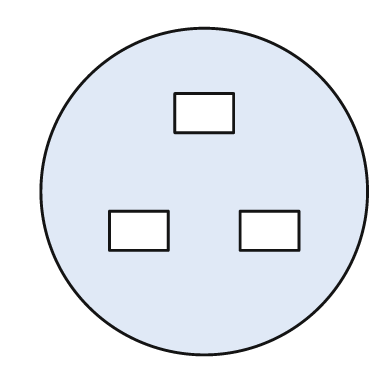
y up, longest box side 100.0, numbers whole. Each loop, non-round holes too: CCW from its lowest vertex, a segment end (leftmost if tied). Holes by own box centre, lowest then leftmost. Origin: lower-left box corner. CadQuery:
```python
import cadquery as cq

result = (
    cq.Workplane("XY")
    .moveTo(50.0, 50.0)
    .circle(50.0)
    .moveTo(21.0, 32.0)
    .lineTo(39.0, 32.0)
    .lineTo(39.0, 44.0)
    .lineTo(21.0, 44.0)
    .close()
    .moveTo(61.0, 32.0)
    .lineTo(79.0, 32.0)
    .lineTo(79.0, 44.0)
    .lineTo(61.0, 44.0)
    .close()
    .moveTo(41.0, 68.0)
    .lineTo(59.0, 68.0)
    .lineTo(59.0, 80.0)
    .lineTo(41.0, 80.0)
    .close()
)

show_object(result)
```